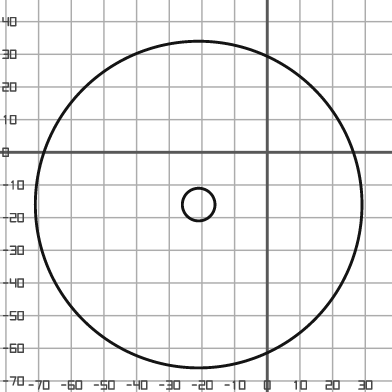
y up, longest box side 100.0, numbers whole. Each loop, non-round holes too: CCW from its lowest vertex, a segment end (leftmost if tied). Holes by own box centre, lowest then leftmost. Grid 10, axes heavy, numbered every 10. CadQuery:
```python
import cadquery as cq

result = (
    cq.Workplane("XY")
    .moveTo(-21.0, -16.0)
    .circle(50.0)
    .moveTo(-21.0, -16.0)
    .circle(5.0)
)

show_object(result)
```